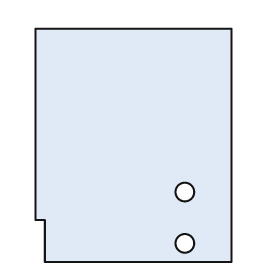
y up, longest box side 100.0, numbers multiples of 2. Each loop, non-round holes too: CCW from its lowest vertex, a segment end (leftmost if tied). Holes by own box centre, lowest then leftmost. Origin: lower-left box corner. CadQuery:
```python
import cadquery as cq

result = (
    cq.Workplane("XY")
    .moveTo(4.0, 0.0)
    .lineTo(84.0, 0.0)
    .lineTo(84.0, 100.0)
    .lineTo(0.0, 100.0)
    .lineTo(0.0, 18.0)
    .lineTo(4.0, 18.0)
    .close()
    .moveTo(64.0, 8.0)
    .circle(4.0)
    .moveTo(64.0, 30.0)
    .circle(4.0)
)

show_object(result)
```